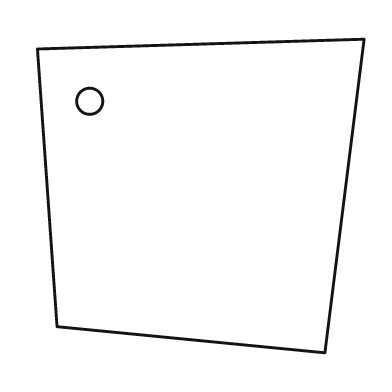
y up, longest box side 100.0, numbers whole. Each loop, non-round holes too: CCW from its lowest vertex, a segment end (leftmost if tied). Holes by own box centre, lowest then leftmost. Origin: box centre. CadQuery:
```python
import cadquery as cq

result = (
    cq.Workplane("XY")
    .moveTo(38.0, -48.0)
    .lineTo(50.0, 48.0)
    .lineTo(-50.0, 45.0)
    .lineTo(-44.0, -40.0)
    .close()
    .moveTo(-34.0, 29.0)
    .circle(4.0)
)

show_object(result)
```